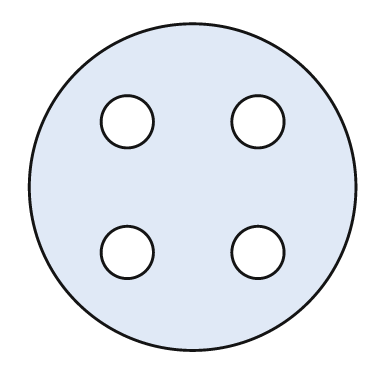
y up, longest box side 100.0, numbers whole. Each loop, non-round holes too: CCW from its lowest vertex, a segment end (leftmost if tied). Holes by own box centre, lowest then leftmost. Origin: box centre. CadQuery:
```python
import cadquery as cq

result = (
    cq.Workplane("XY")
    .moveTo(0.0, 0.0)
    .circle(50.0)
    .moveTo(-20.0, -20.0)
    .circle(8.0)
    .moveTo(20.0, -20.0)
    .circle(8.0)
    .moveTo(-20.0, 20.0)
    .circle(8.0)
    .moveTo(20.0, 20.0)
    .circle(8.0)
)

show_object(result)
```